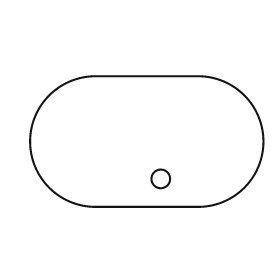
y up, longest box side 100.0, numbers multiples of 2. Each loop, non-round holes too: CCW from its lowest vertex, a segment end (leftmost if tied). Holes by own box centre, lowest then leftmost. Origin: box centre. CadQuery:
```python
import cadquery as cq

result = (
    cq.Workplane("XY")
    .moveTo(-22.0, -28.0)
    .lineTo(22.0, -28.0)
    .threePointArc((50.0, 0.0), (22.0, 28.0))
    .lineTo(-22.0, 28.0)
    .threePointArc((-50.0, 0.0), (-22.0, -28.0))
    .close()
    .moveTo(6.0, -16.0)
    .circle(4.0)
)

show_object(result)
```